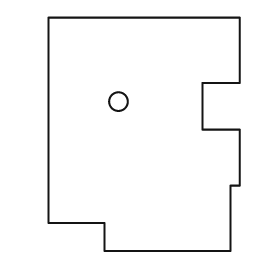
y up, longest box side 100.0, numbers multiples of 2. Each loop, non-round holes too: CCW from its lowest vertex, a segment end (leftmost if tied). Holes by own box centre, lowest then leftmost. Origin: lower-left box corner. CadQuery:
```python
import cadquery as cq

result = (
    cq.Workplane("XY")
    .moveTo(24.0, 0.0)
    .lineTo(78.0, 0.0)
    .lineTo(78.0, 28.0)
    .lineTo(82.0, 28.0)
    .lineTo(82.0, 52.0)
    .lineTo(66.0, 52.0)
    .lineTo(66.0, 72.0)
    .lineTo(82.0, 72.0)
    .lineTo(82.0, 100.0)
    .lineTo(0.0, 100.0)
    .lineTo(0.0, 12.0)
    .lineTo(24.0, 12.0)
    .close()
    .moveTo(30.0, 64.0)
    .circle(4.0)
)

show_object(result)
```